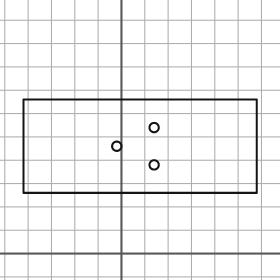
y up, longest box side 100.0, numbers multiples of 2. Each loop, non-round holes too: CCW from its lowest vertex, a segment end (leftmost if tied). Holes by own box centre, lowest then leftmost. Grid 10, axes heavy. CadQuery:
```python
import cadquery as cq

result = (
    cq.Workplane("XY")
    .moveTo(-42.0, 26.0)
    .lineTo(58.0, 26.0)
    .lineTo(58.0, 66.0)
    .lineTo(-42.0, 66.0)
    .close()
    .moveTo(14.0, 38.0)
    .circle(2.0)
    .moveTo(-2.0, 46.0)
    .circle(2.0)
    .moveTo(14.0, 54.0)
    .circle(2.0)
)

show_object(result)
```